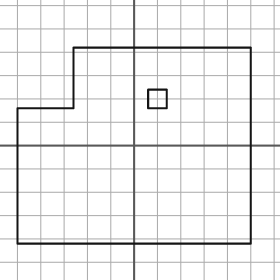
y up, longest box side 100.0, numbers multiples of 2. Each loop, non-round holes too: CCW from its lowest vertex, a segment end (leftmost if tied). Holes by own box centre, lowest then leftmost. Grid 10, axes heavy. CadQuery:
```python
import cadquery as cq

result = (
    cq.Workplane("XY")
    .moveTo(-50.0, -42.0)
    .lineTo(50.0, -42.0)
    .lineTo(50.0, 42.0)
    .lineTo(-26.0, 42.0)
    .lineTo(-26.0, 16.0)
    .lineTo(-50.0, 16.0)
    .close()
    .moveTo(6.0, 16.0)
    .lineTo(14.0, 16.0)
    .lineTo(14.0, 24.0)
    .lineTo(6.0, 24.0)
    .close()
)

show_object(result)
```